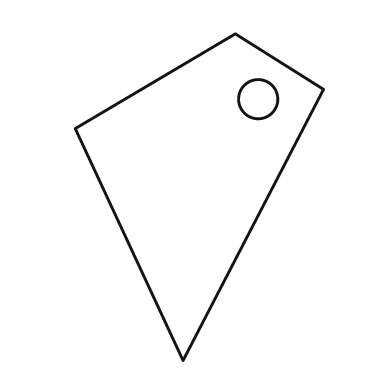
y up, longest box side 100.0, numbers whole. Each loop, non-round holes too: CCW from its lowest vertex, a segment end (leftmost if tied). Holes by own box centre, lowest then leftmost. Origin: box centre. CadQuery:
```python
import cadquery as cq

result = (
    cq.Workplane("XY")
    .moveTo(-5.0, -50.0)
    .lineTo(38.0, 33.0)
    .lineTo(11.0, 50.0)
    .lineTo(-38.0, 21.0)
    .close()
    .moveTo(18.0, 30.0)
    .circle(6.0)
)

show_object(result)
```